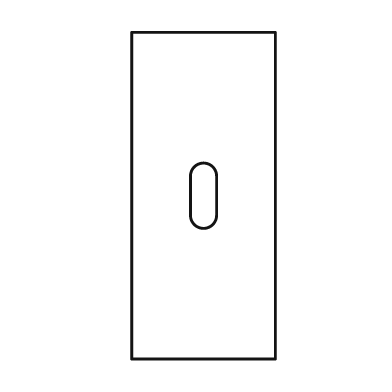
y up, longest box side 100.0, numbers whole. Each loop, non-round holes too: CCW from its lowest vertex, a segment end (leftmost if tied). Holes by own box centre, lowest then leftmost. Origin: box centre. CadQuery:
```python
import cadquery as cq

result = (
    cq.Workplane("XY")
    .moveTo(-22.0, -50.0)
    .lineTo(22.0, -50.0)
    .lineTo(22.0, 50.0)
    .lineTo(-22.0, 50.0)
    .close()
    .moveTo(-4.0, -6.0)
    .threePointArc((0.0, -10.0), (4.0, -6.0))
    .lineTo(4.0, 6.0)
    .threePointArc((0.0, 10.0), (-4.0, 6.0))
    .close()
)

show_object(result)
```